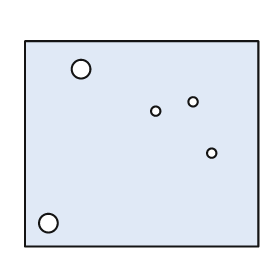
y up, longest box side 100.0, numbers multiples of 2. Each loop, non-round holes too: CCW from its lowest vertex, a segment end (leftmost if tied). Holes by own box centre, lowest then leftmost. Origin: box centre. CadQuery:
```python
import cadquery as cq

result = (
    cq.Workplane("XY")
    .moveTo(-50.0, -44.0)
    .lineTo(50.0, -44.0)
    .lineTo(50.0, 44.0)
    .lineTo(-50.0, 44.0)
    .close()
    .moveTo(-40.0, -34.0)
    .circle(4.0)
    .moveTo(30.0, -4.0)
    .circle(2.0)
    .moveTo(6.0, 14.0)
    .circle(2.0)
    .moveTo(22.0, 18.0)
    .circle(2.0)
    .moveTo(-26.0, 32.0)
    .circle(4.0)
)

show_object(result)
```